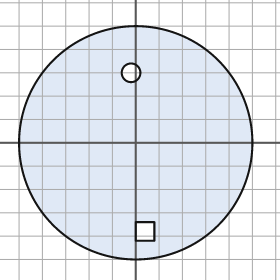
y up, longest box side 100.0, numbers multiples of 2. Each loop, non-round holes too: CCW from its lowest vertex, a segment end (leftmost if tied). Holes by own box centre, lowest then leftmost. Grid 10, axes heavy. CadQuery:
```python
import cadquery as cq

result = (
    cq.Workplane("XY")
    .moveTo(0.0, 0.0)
    .circle(50.0)
    .moveTo(0.0, -42.0)
    .lineTo(8.0, -42.0)
    .lineTo(8.0, -34.0)
    .lineTo(0.0, -34.0)
    .close()
    .moveTo(-2.0, 30.0)
    .circle(4.0)
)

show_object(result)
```